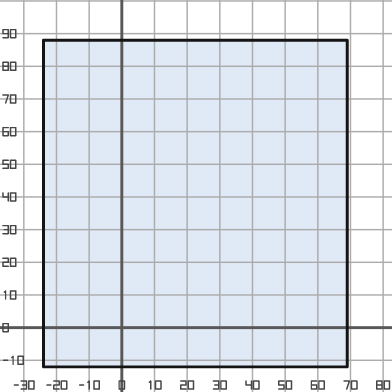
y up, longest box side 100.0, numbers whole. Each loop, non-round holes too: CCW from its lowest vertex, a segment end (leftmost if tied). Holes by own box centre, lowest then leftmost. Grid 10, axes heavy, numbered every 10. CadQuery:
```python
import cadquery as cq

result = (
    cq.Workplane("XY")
    .moveTo(-24.0, -12.0)
    .lineTo(69.0, -12.0)
    .lineTo(69.0, 88.0)
    .lineTo(-24.0, 88.0)
    .close()
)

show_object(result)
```